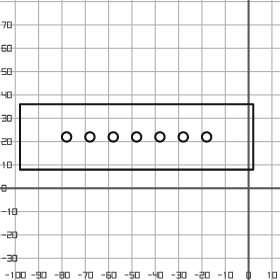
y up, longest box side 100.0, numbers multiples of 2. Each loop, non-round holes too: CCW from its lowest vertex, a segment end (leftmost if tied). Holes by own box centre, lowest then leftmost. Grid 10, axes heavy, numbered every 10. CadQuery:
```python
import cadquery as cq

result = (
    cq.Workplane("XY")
    .moveTo(-98.0, 8.0)
    .lineTo(2.0, 8.0)
    .lineTo(2.0, 36.0)
    .lineTo(-98.0, 36.0)
    .close()
    .moveTo(-78.0, 22.0)
    .circle(2.0)
    .moveTo(-68.0, 22.0)
    .circle(2.0)
    .moveTo(-58.0, 22.0)
    .circle(2.0)
    .moveTo(-48.0, 22.0)
    .circle(2.0)
    .moveTo(-38.0, 22.0)
    .circle(2.0)
    .moveTo(-28.0, 22.0)
    .circle(2.0)
    .moveTo(-18.0, 22.0)
    .circle(2.0)
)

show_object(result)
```